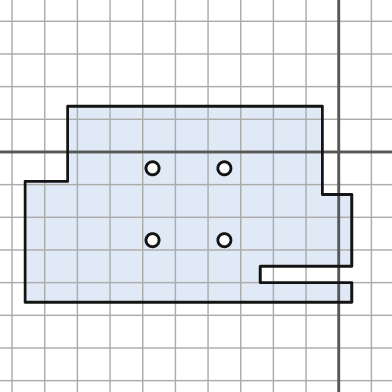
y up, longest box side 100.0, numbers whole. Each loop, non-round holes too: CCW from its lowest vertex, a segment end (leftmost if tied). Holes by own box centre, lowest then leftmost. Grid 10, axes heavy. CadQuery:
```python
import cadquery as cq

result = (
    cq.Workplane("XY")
    .moveTo(-96.0, -46.0)
    .lineTo(4.0, -46.0)
    .lineTo(4.0, -40.0)
    .lineTo(-24.0, -40.0)
    .lineTo(-24.0, -35.0)
    .lineTo(4.0, -35.0)
    .lineTo(4.0, -13.0)
    .lineTo(-5.0, -13.0)
    .lineTo(-5.0, 14.0)
    .lineTo(-83.0, 14.0)
    .lineTo(-83.0, -9.0)
    .lineTo(-96.0, -9.0)
    .close()
    .moveTo(-57.0, -27.0)
    .circle(2.0)
    .moveTo(-35.0, -27.0)
    .circle(2.0)
    .moveTo(-57.0, -5.0)
    .circle(2.0)
    .moveTo(-35.0, -5.0)
    .circle(2.0)
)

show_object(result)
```